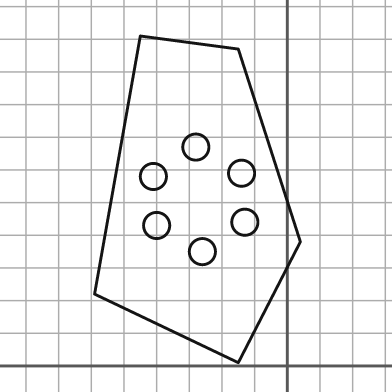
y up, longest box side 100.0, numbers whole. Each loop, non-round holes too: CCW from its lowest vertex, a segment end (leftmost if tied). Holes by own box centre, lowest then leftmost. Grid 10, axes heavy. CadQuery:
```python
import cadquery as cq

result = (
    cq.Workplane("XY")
    .moveTo(-15.0, 1.0)
    .lineTo(4.0, 38.0)
    .lineTo(-15.0, 97.0)
    .lineTo(-45.0, 101.0)
    .lineTo(-59.0, 22.0)
    .close()
    .moveTo(-26.0, 35.0)
    .circle(4.0)
    .moveTo(-40.0, 43.0)
    .circle(4.0)
    .moveTo(-13.0, 44.0)
    .circle(4.0)
    .moveTo(-41.0, 58.0)
    .circle(4.0)
    .moveTo(-14.0, 59.0)
    .circle(4.0)
    .moveTo(-28.0, 67.0)
    .circle(4.0)
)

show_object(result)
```